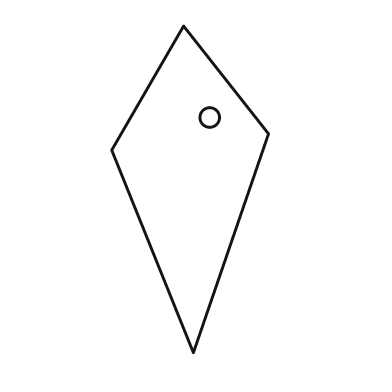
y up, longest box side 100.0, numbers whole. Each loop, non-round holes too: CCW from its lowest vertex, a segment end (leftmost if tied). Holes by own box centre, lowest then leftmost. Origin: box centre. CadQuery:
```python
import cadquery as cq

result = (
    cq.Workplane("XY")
    .moveTo(1.0, -50.0)
    .lineTo(24.0, 17.0)
    .lineTo(-2.0, 50.0)
    .lineTo(-24.0, 12.0)
    .close()
    .moveTo(6.0, 22.0)
    .circle(3.0)
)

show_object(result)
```